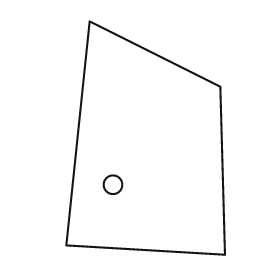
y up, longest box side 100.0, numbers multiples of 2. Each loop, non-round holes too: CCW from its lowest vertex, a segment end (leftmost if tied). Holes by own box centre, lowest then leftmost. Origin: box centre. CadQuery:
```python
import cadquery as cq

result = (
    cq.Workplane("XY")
    .moveTo(34.0, -50.0)
    .lineTo(32.0, 22.0)
    .lineTo(-24.0, 50.0)
    .lineTo(-34.0, -46.0)
    .close()
    .moveTo(-14.0, -20.0)
    .circle(4.0)
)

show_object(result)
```